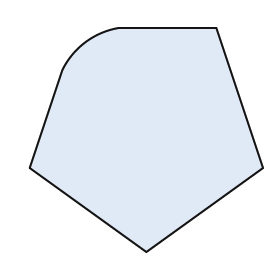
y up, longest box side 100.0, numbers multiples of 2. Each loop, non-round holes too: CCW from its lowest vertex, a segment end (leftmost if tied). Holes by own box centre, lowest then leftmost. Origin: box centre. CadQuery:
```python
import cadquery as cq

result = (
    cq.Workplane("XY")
    .moveTo(0.0, -48.0)
    .lineTo(50.0, -12.0)
    .lineTo(30.0, 48.0)
    .lineTo(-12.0, 48.0)
    .threePointArc((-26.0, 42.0), (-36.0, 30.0))
    .lineTo(-50.0, -12.0)
    .close()
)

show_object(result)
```